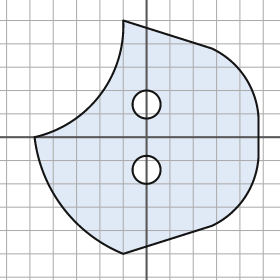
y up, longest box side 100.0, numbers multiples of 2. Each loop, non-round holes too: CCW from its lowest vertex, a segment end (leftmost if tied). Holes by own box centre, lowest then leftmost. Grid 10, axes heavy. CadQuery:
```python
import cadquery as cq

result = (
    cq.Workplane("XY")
    .moveTo(-10.0, -50.0)
    .lineTo(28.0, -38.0)
    .threePointArc((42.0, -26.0), (48.0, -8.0))
    .lineTo(48.0, 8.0)
    .threePointArc((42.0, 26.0), (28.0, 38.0))
    .lineTo(-10.0, 50.0)
    .threePointArc((-20.0, 18.0), (-48.0, 0.0))
    .threePointArc((-36.0, -30.0), (-10.0, -50.0))
    .close()
    .moveTo(0.0, -14.0)
    .circle(6.0)
    .moveTo(0.0, 14.0)
    .circle(6.0)
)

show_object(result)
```